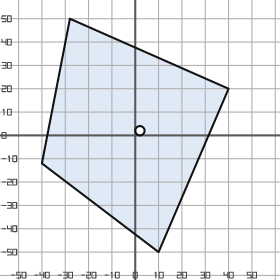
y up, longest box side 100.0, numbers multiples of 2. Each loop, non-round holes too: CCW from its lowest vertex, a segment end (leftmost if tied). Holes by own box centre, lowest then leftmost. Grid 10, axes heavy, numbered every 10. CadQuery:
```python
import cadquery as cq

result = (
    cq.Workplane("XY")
    .moveTo(10.0, -50.0)
    .lineTo(40.0, 20.0)
    .lineTo(-28.0, 50.0)
    .lineTo(-40.0, -12.0)
    .close()
    .moveTo(2.0, 2.0)
    .circle(2.0)
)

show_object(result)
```